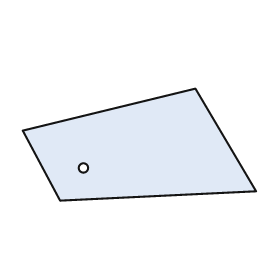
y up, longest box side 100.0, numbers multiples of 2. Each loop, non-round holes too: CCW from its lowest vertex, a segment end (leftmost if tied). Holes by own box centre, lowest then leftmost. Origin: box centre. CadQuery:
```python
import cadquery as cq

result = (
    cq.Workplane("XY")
    .moveTo(-34.0, -24.0)
    .lineTo(50.0, -20.0)
    .lineTo(24.0, 24.0)
    .lineTo(-50.0, 6.0)
    .close()
    .moveTo(-24.0, -10.0)
    .circle(2.0)
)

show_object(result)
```